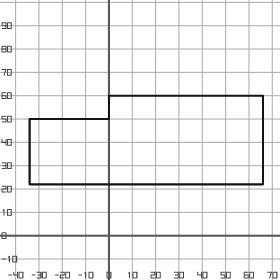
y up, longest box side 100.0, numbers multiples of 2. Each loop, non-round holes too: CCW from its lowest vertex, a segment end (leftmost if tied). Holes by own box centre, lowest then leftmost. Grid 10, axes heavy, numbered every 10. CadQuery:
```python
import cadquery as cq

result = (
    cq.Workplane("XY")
    .moveTo(-34.0, 22.0)
    .lineTo(66.0, 22.0)
    .lineTo(66.0, 60.0)
    .lineTo(0.0, 60.0)
    .lineTo(0.0, 50.0)
    .lineTo(-34.0, 50.0)
    .close()
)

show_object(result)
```